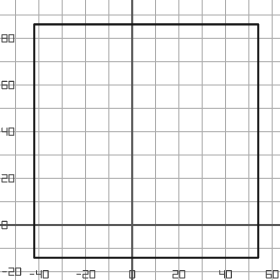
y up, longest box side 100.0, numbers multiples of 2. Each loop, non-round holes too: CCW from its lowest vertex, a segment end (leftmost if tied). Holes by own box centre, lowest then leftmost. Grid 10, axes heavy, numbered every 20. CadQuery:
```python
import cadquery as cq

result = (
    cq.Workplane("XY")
    .moveTo(-42.0, -14.0)
    .lineTo(54.0, -14.0)
    .lineTo(54.0, 86.0)
    .lineTo(-42.0, 86.0)
    .close()
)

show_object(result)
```